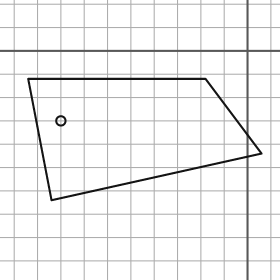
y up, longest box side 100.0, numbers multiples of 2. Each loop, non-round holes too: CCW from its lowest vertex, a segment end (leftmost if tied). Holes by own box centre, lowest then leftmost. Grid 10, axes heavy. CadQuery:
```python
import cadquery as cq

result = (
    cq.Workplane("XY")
    .moveTo(-84.0, -64.0)
    .lineTo(6.0, -44.0)
    .lineTo(-18.0, -12.0)
    .lineTo(-94.0, -12.0)
    .close()
    .moveTo(-80.0, -30.0)
    .circle(2.0)
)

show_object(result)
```